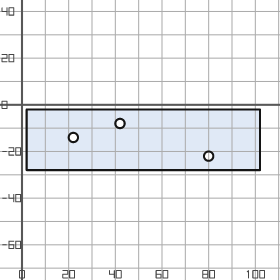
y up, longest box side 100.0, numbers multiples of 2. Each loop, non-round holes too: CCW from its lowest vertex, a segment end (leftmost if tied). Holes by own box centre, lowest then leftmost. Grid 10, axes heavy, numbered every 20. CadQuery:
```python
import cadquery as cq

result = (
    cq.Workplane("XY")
    .moveTo(2.0, -28.0)
    .lineTo(102.0, -28.0)
    .lineTo(102.0, -2.0)
    .lineTo(2.0, -2.0)
    .close()
    .moveTo(80.0, -22.0)
    .circle(2.0)
    .moveTo(22.0, -14.0)
    .circle(2.0)
    .moveTo(42.0, -8.0)
    .circle(2.0)
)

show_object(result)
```